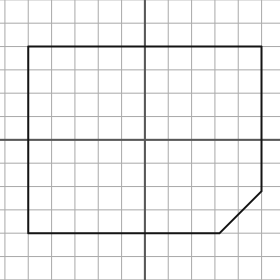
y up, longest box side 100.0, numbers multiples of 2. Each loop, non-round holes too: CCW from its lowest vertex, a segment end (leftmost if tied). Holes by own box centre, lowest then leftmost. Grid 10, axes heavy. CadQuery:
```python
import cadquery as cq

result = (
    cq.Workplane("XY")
    .moveTo(-50.0, -40.0)
    .lineTo(32.0, -40.0)
    .lineTo(50.0, -22.0)
    .lineTo(50.0, 40.0)
    .lineTo(-50.0, 40.0)
    .close()
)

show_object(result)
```